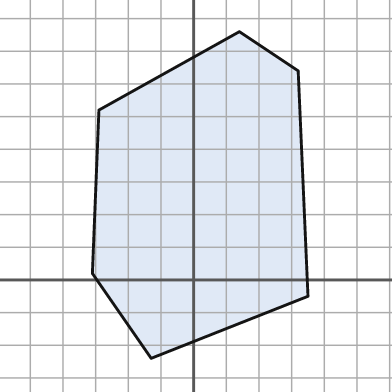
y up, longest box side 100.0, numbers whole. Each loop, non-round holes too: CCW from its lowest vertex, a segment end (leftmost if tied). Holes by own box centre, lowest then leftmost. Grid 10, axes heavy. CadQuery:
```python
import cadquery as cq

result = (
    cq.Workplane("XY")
    .moveTo(-13.0, -24.0)
    .lineTo(35.0, -5.0)
    .lineTo(32.0, 64.0)
    .lineTo(14.0, 76.0)
    .lineTo(-29.0, 52.0)
    .lineTo(-31.0, 2.0)
    .close()
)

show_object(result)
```